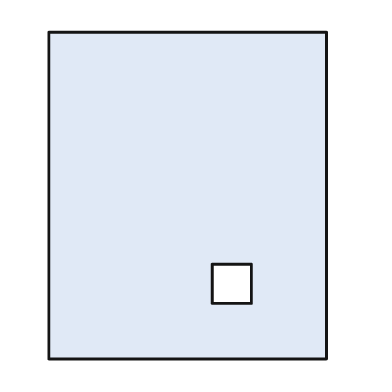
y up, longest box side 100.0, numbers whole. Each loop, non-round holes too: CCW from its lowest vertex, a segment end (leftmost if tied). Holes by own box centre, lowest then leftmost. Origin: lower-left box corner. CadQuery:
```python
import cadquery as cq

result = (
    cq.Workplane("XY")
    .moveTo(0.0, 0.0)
    .lineTo(85.0, 0.0)
    .lineTo(85.0, 100.0)
    .lineTo(0.0, 100.0)
    .close()
    .moveTo(50.0, 17.0)
    .lineTo(62.0, 17.0)
    .lineTo(62.0, 29.0)
    .lineTo(50.0, 29.0)
    .close()
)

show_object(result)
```